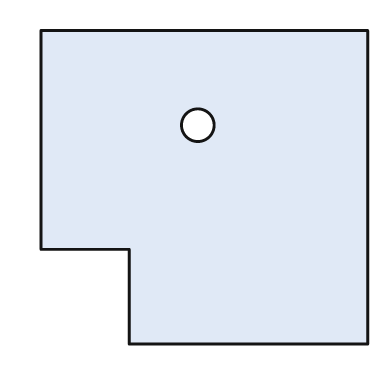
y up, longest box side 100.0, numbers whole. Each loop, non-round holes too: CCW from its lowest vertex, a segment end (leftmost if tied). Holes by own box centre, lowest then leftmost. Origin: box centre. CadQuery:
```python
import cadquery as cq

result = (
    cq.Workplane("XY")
    .moveTo(-23.0, -48.0)
    .lineTo(50.0, -48.0)
    .lineTo(50.0, 48.0)
    .lineTo(-50.0, 48.0)
    .lineTo(-50.0, -19.0)
    .lineTo(-23.0, -19.0)
    .close()
    .moveTo(-2.0, 19.0)
    .circle(5.0)
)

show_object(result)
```